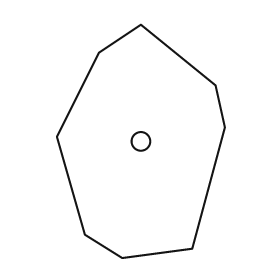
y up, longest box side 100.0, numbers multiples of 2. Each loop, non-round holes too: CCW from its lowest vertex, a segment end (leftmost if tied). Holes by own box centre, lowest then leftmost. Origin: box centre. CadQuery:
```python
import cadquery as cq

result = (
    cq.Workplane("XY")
    .moveTo(-8.0, -50.0)
    .lineTo(22.0, -46.0)
    .lineTo(36.0, 6.0)
    .lineTo(32.0, 24.0)
    .lineTo(0.0, 50.0)
    .lineTo(-18.0, 38.0)
    .lineTo(-36.0, 2.0)
    .lineTo(-24.0, -40.0)
    .close()
    .moveTo(0.0, 0.0)
    .circle(4.0)
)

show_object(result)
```